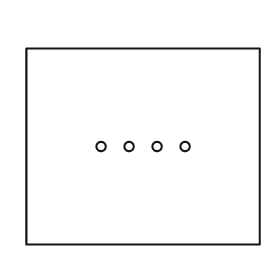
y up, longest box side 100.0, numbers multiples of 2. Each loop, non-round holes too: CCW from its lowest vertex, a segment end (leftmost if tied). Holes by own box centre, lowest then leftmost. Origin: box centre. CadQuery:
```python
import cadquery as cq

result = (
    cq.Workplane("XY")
    .moveTo(-50.0, -42.0)
    .lineTo(50.0, -42.0)
    .lineTo(50.0, 42.0)
    .lineTo(-50.0, 42.0)
    .close()
    .moveTo(-18.0, 0.0)
    .circle(2.0)
    .moveTo(-6.0, 0.0)
    .circle(2.0)
    .moveTo(6.0, 0.0)
    .circle(2.0)
    .moveTo(18.0, 0.0)
    .circle(2.0)
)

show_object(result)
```